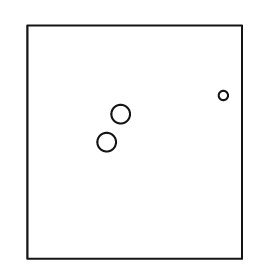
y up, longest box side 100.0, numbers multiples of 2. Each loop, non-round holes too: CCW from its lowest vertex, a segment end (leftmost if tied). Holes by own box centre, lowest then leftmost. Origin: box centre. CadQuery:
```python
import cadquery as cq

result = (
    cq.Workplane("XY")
    .moveTo(-46.0, -50.0)
    .lineTo(46.0, -50.0)
    .lineTo(46.0, 50.0)
    .lineTo(-46.0, 50.0)
    .close()
    .moveTo(-12.0, 0.0)
    .circle(4.0)
    .moveTo(-6.0, 12.0)
    .circle(4.0)
    .moveTo(38.0, 20.0)
    .circle(2.0)
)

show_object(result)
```